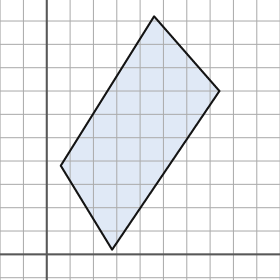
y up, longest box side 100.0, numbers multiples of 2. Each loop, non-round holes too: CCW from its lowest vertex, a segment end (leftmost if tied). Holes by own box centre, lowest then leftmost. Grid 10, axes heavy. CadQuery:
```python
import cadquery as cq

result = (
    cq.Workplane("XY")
    .moveTo(28.0, 2.0)
    .lineTo(74.0, 70.0)
    .lineTo(46.0, 102.0)
    .lineTo(6.0, 38.0)
    .close()
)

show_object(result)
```